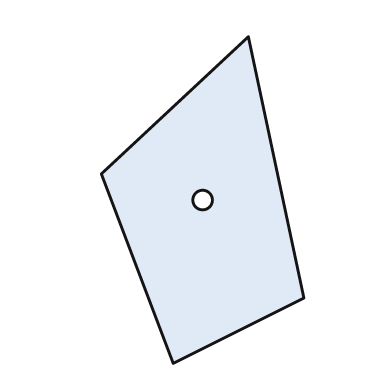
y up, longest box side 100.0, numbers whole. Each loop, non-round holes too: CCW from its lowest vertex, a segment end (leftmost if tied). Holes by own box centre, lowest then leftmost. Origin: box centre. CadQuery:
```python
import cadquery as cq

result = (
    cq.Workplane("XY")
    .moveTo(-9.0, -50.0)
    .lineTo(31.0, -30.0)
    .lineTo(14.0, 50.0)
    .lineTo(-31.0, 8.0)
    .close()
    .moveTo(0.0, 0.0)
    .circle(3.0)
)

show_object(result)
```